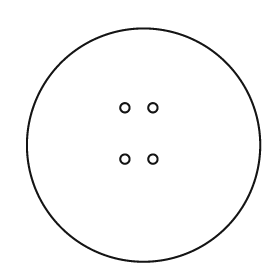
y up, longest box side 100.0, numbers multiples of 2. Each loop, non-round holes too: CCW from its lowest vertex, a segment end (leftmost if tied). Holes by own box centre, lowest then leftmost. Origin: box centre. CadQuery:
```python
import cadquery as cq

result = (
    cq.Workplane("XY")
    .moveTo(0.0, 0.0)
    .circle(50.0)
    .moveTo(-8.0, -6.0)
    .circle(2.0)
    .moveTo(4.0, -6.0)
    .circle(2.0)
    .moveTo(-8.0, 16.0)
    .circle(2.0)
    .moveTo(4.0, 16.0)
    .circle(2.0)
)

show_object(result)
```